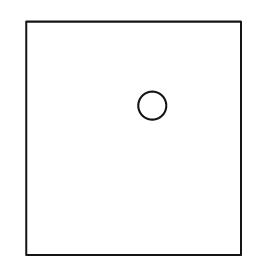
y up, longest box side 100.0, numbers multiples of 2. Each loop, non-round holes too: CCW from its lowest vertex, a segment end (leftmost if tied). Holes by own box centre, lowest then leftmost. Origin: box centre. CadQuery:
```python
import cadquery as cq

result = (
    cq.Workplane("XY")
    .moveTo(-46.0, -50.0)
    .lineTo(46.0, -50.0)
    .lineTo(46.0, 50.0)
    .lineTo(-46.0, 50.0)
    .close()
    .moveTo(8.0, 14.0)
    .circle(6.0)
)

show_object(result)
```